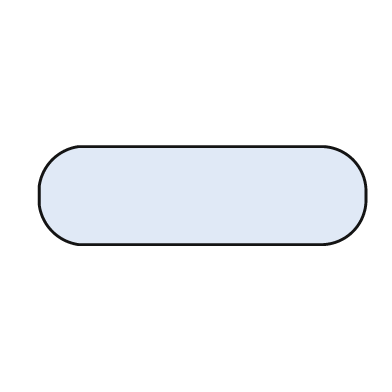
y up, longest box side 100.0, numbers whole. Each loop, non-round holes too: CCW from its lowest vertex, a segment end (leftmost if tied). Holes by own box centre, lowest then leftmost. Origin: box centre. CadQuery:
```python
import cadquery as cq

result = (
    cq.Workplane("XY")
    .moveTo(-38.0, -15.0)
    .lineTo(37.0, -15.0)
    .threePointArc((46.0, -11.0), (50.0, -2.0))
    .lineTo(50.0, 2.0)
    .threePointArc((46.0, 11.0), (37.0, 15.0))
    .lineTo(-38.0, 15.0)
    .threePointArc((-46.0, 11.0), (-50.0, 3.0))
    .lineTo(-50.0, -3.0)
    .threePointArc((-46.0, -11.0), (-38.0, -15.0))
    .close()
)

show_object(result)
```